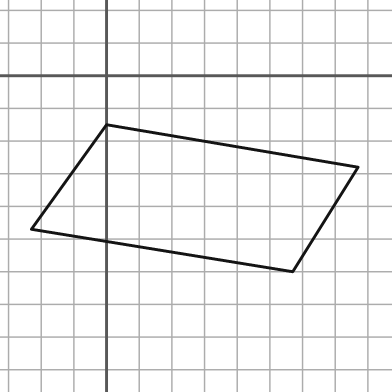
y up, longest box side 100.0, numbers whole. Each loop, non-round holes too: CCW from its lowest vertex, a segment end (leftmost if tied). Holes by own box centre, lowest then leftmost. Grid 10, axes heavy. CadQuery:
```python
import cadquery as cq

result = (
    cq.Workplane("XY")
    .moveTo(57.0, -60.0)
    .lineTo(77.0, -28.0)
    .lineTo(0.0, -15.0)
    .lineTo(-23.0, -47.0)
    .close()
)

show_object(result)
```